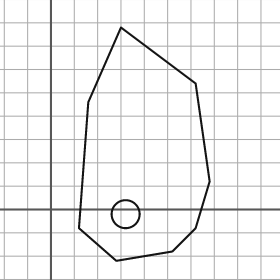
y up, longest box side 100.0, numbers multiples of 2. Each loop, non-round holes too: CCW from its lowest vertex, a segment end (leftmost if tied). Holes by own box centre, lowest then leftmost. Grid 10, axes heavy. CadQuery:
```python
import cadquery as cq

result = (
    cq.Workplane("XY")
    .moveTo(28.0, -22.0)
    .lineTo(52.0, -18.0)
    .lineTo(62.0, -8.0)
    .lineTo(68.0, 12.0)
    .lineTo(62.0, 54.0)
    .lineTo(30.0, 78.0)
    .lineTo(16.0, 46.0)
    .lineTo(12.0, -8.0)
    .close()
    .moveTo(32.0, -2.0)
    .circle(6.0)
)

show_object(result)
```